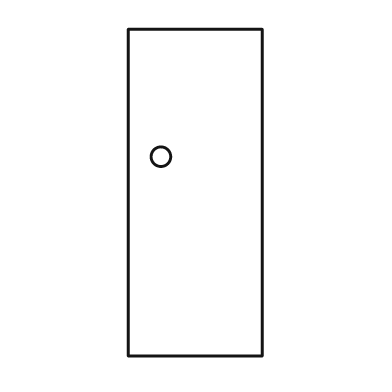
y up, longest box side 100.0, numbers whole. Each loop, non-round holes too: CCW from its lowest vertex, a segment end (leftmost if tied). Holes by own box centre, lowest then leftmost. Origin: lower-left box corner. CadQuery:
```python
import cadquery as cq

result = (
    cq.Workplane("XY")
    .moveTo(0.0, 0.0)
    .lineTo(41.0, 0.0)
    .lineTo(41.0, 100.0)
    .lineTo(0.0, 100.0)
    .close()
    .moveTo(10.0, 61.0)
    .circle(3.0)
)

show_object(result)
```